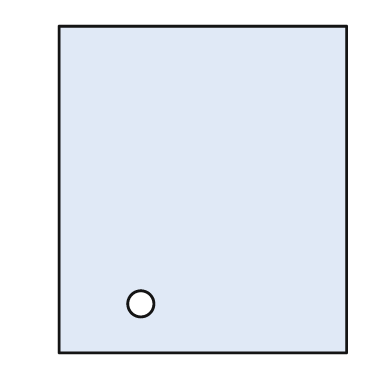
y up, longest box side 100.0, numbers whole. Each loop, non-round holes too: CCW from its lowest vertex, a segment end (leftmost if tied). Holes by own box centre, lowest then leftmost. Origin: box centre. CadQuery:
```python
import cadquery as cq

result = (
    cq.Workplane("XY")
    .moveTo(-44.0, -50.0)
    .lineTo(44.0, -50.0)
    .lineTo(44.0, 50.0)
    .lineTo(-44.0, 50.0)
    .close()
    .moveTo(-19.0, -35.0)
    .circle(4.0)
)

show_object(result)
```